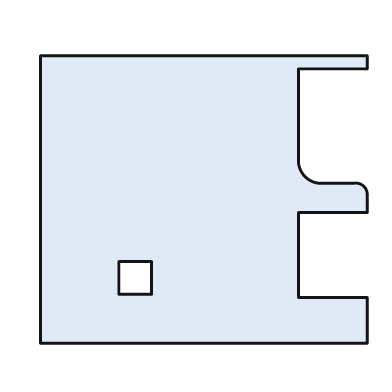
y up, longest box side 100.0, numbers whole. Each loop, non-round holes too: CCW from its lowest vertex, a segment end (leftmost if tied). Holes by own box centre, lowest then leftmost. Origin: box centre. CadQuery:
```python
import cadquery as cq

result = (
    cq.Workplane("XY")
    .moveTo(-50.0, -44.0)
    .lineTo(50.0, -44.0)
    .lineTo(50.0, -30.0)
    .lineTo(29.0, -30.0)
    .lineTo(29.0, -4.0)
    .lineTo(50.0, -4.0)
    .lineTo(50.0, 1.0)
    .threePointArc((49.0, 4.0), (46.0, 5.0))
    .lineTo(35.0, 5.0)
    .threePointArc((31.0, 7.0), (29.0, 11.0))
    .lineTo(29.0, 40.0)
    .lineTo(50.0, 40.0)
    .lineTo(50.0, 44.0)
    .lineTo(-50.0, 44.0)
    .close()
    .moveTo(-26.0, -29.0)
    .lineTo(-16.0, -29.0)
    .lineTo(-16.0, -19.0)
    .lineTo(-26.0, -19.0)
    .close()
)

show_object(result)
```